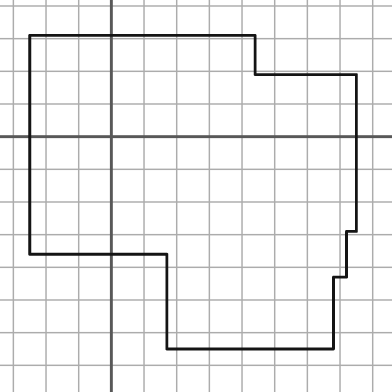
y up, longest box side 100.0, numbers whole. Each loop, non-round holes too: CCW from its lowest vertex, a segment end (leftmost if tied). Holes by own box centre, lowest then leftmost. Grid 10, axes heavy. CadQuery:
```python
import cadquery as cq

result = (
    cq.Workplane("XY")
    .moveTo(17.0, -65.0)
    .lineTo(68.0, -65.0)
    .lineTo(68.0, -43.0)
    .lineTo(72.0, -43.0)
    .lineTo(72.0, -29.0)
    .lineTo(75.0, -29.0)
    .lineTo(75.0, 19.0)
    .lineTo(44.0, 19.0)
    .lineTo(44.0, 31.0)
    .lineTo(-25.0, 31.0)
    .lineTo(-25.0, -36.0)
    .lineTo(17.0, -36.0)
    .close()
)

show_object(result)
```